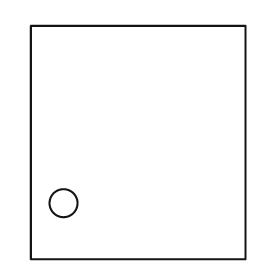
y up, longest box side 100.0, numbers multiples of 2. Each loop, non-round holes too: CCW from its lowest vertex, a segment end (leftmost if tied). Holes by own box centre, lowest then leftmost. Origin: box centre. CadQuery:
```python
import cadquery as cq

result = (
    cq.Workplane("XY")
    .moveTo(-46.0, -50.0)
    .lineTo(46.0, -50.0)
    .lineTo(46.0, 50.0)
    .lineTo(-46.0, 50.0)
    .close()
    .moveTo(-32.0, -26.0)
    .circle(6.0)
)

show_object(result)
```